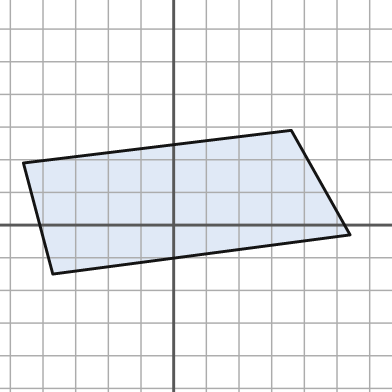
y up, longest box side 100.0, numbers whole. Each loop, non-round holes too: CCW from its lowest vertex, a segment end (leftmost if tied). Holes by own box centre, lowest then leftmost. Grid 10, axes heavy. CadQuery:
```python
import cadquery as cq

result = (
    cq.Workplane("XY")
    .moveTo(-37.0, -15.0)
    .lineTo(54.0, -3.0)
    .lineTo(36.0, 29.0)
    .lineTo(-46.0, 19.0)
    .close()
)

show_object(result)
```